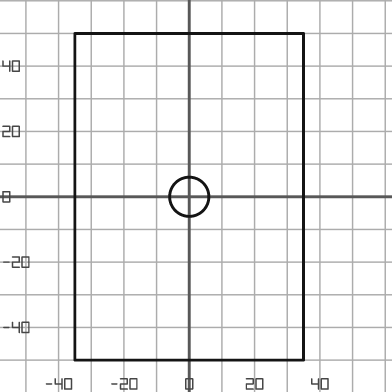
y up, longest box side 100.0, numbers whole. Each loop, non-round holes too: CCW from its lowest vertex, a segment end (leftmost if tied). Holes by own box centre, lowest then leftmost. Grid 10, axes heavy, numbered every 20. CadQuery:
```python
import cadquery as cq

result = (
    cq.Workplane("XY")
    .moveTo(-35.0, -50.0)
    .lineTo(35.0, -50.0)
    .lineTo(35.0, 50.0)
    .lineTo(-35.0, 50.0)
    .close()
    .moveTo(0.0, 0.0)
    .circle(6.0)
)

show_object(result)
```